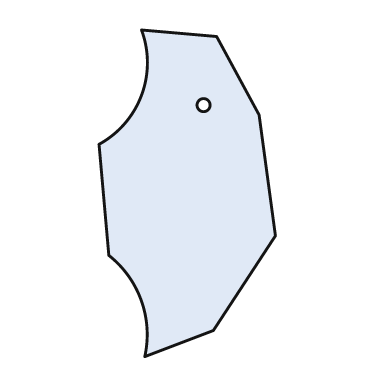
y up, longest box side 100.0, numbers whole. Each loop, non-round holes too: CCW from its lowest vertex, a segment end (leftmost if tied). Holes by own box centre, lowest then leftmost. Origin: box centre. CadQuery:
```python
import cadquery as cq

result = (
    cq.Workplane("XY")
    .moveTo(-13.0, -50.0)
    .lineTo(8.0, -42.0)
    .lineTo(27.0, -13.0)
    .lineTo(22.0, 24.0)
    .lineTo(9.0, 48.0)
    .lineTo(-14.0, 50.0)
    .threePointArc((-14.0, 30.0), (-27.0, 15.0))
    .lineTo(-24.0, -19.0)
    .threePointArc((-14.0, -33.0), (-13.0, -50.0))
    .close()
    .moveTo(5.0, 27.0)
    .circle(2.0)
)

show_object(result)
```